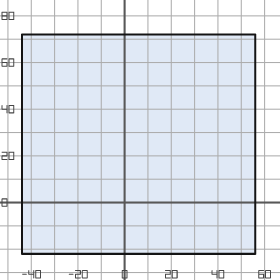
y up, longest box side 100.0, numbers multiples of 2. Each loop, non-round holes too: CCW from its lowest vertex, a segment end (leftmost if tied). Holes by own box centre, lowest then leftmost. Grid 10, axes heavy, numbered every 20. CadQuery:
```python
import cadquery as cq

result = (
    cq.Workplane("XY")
    .moveTo(-44.0, -22.0)
    .lineTo(56.0, -22.0)
    .lineTo(56.0, 72.0)
    .lineTo(-44.0, 72.0)
    .close()
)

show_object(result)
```